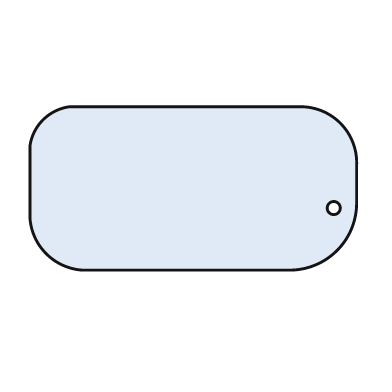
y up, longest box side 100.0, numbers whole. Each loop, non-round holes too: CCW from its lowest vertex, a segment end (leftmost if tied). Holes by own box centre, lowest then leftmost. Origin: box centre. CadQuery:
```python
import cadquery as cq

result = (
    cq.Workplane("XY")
    .moveTo(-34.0, -25.0)
    .lineTo(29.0, -25.0)
    .threePointArc((44.0, -19.0), (50.0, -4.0))
    .lineTo(50.0, 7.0)
    .threePointArc((45.0, 20.0), (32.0, 25.0))
    .lineTo(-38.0, 25.0)
    .threePointArc((-46.0, 21.0), (-50.0, 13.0))
    .lineTo(-50.0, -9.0)
    .threePointArc((-45.0, -20.0), (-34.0, -25.0))
    .close()
    .moveTo(43.0, -6.0)
    .circle(2.0)
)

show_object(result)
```